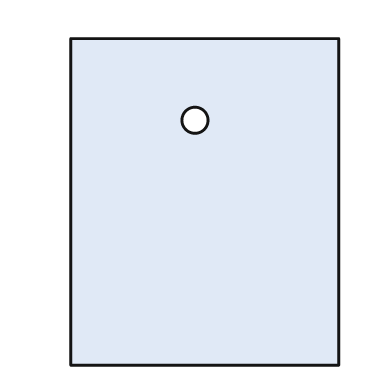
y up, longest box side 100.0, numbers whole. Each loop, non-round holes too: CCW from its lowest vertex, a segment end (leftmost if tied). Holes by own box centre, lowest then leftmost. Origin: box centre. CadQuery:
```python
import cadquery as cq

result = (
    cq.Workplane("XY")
    .moveTo(-41.0, -50.0)
    .lineTo(41.0, -50.0)
    .lineTo(41.0, 50.0)
    .lineTo(-41.0, 50.0)
    .close()
    .moveTo(-3.0, 25.0)
    .circle(4.0)
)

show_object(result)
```